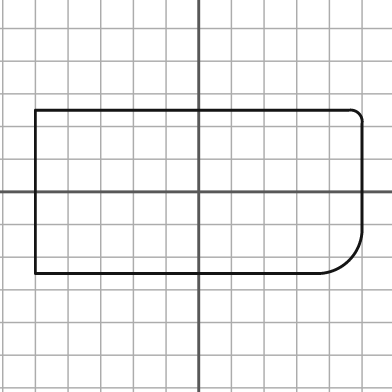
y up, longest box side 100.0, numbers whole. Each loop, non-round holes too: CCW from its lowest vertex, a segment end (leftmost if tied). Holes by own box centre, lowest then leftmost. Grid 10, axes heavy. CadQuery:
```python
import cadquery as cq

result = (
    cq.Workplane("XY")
    .moveTo(-50.0, -25.0)
    .lineTo(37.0, -25.0)
    .threePointArc((46.0, -21.0), (50.0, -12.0))
    .lineTo(50.0, 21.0)
    .threePointArc((49.0, 24.0), (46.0, 25.0))
    .lineTo(-50.0, 25.0)
    .close()
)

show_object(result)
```